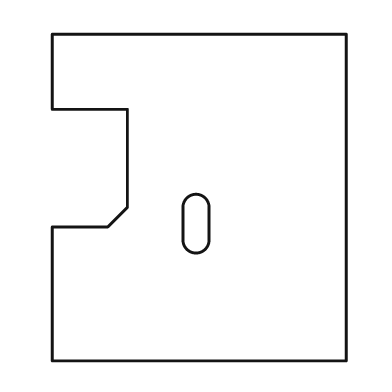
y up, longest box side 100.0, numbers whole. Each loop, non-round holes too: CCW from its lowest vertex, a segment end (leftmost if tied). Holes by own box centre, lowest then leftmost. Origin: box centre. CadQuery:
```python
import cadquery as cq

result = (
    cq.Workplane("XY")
    .moveTo(-45.0, -50.0)
    .lineTo(45.0, -50.0)
    .lineTo(45.0, 50.0)
    .lineTo(-45.0, 50.0)
    .lineTo(-45.0, 27.0)
    .lineTo(-22.0, 27.0)
    .lineTo(-22.0, -3.0)
    .lineTo(-28.0, -9.0)
    .lineTo(-45.0, -9.0)
    .close()
    .moveTo(-5.0, -13.0)
    .threePointArc((-1.0, -17.0), (3.0, -13.0))
    .lineTo(3.0, -3.0)
    .threePointArc((-1.0, 1.0), (-5.0, -3.0))
    .close()
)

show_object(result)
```